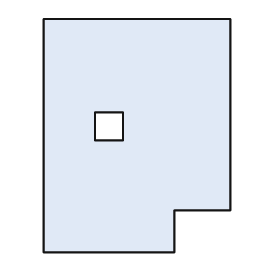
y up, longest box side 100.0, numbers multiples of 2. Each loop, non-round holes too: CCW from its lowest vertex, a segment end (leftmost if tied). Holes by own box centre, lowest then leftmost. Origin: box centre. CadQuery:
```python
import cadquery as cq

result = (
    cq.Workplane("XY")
    .moveTo(-40.0, -50.0)
    .lineTo(16.0, -50.0)
    .lineTo(16.0, -32.0)
    .lineTo(40.0, -32.0)
    .lineTo(40.0, 50.0)
    .lineTo(-40.0, 50.0)
    .close()
    .moveTo(-18.0, -2.0)
    .lineTo(-6.0, -2.0)
    .lineTo(-6.0, 10.0)
    .lineTo(-18.0, 10.0)
    .close()
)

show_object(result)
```